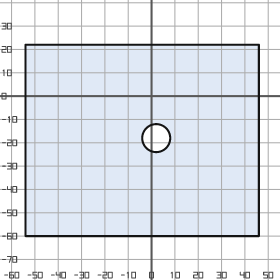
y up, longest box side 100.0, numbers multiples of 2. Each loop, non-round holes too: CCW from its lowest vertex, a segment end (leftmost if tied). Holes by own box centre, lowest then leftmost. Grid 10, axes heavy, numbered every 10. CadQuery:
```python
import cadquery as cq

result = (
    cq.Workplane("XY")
    .moveTo(-54.0, -60.0)
    .lineTo(46.0, -60.0)
    .lineTo(46.0, 22.0)
    .lineTo(-54.0, 22.0)
    .close()
    .moveTo(2.0, -18.0)
    .circle(6.0)
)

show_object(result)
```